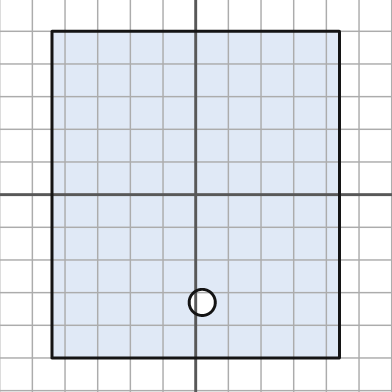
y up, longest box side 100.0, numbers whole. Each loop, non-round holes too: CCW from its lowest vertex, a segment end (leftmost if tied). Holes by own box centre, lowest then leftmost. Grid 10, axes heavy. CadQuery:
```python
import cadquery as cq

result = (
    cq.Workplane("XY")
    .moveTo(-44.0, -50.0)
    .lineTo(44.0, -50.0)
    .lineTo(44.0, 50.0)
    .lineTo(-44.0, 50.0)
    .close()
    .moveTo(2.0, -33.0)
    .circle(4.0)
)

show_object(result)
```